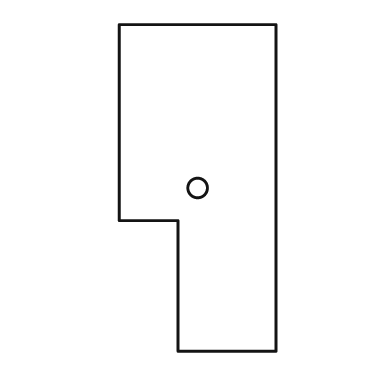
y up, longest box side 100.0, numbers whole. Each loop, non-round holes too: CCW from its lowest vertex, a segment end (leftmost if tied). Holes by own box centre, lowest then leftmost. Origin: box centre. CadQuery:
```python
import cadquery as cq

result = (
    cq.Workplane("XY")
    .moveTo(-6.0, -50.0)
    .lineTo(24.0, -50.0)
    .lineTo(24.0, 50.0)
    .lineTo(-24.0, 50.0)
    .lineTo(-24.0, -10.0)
    .lineTo(-6.0, -10.0)
    .close()
    .moveTo(0.0, 0.0)
    .circle(3.0)
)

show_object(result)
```